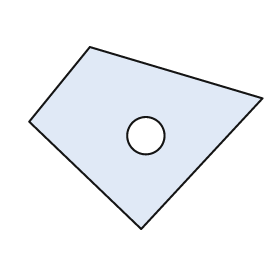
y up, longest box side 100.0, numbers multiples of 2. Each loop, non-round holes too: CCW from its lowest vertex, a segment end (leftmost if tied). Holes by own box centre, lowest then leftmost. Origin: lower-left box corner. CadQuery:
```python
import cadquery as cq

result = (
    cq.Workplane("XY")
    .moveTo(48.0, 0.0)
    .lineTo(100.0, 56.0)
    .lineTo(26.0, 78.0)
    .lineTo(0.0, 46.0)
    .close()
    .moveTo(50.0, 40.0)
    .circle(8.0)
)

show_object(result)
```